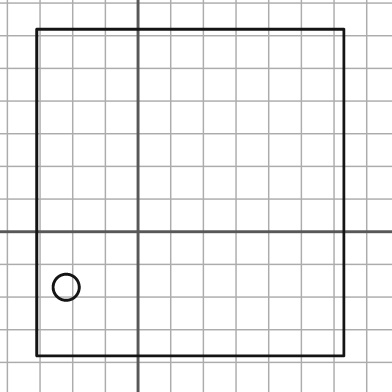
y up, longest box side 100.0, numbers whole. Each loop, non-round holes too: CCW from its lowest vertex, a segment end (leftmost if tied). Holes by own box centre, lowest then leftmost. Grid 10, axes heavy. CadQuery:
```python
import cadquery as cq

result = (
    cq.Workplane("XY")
    .moveTo(-31.0, -38.0)
    .lineTo(63.0, -38.0)
    .lineTo(63.0, 62.0)
    .lineTo(-31.0, 62.0)
    .close()
    .moveTo(-22.0, -17.0)
    .circle(4.0)
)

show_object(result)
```